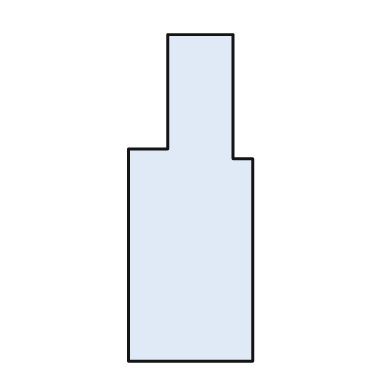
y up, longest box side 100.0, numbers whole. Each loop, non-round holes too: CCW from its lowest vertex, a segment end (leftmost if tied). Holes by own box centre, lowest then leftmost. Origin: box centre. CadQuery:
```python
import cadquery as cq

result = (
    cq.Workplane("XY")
    .moveTo(-19.0, -50.0)
    .lineTo(19.0, -50.0)
    .lineTo(19.0, 12.0)
    .lineTo(13.0, 12.0)
    .lineTo(13.0, 50.0)
    .lineTo(-7.0, 50.0)
    .lineTo(-7.0, 15.0)
    .lineTo(-19.0, 15.0)
    .close()
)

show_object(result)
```